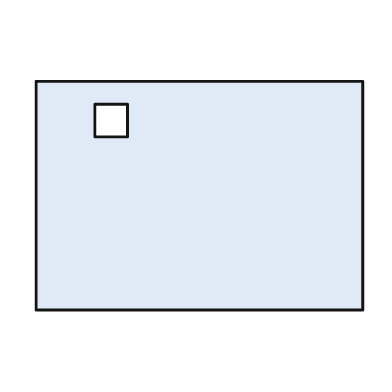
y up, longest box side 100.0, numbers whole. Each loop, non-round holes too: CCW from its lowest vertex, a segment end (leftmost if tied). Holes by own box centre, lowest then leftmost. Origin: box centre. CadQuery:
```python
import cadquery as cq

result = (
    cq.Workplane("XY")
    .moveTo(-50.0, -35.0)
    .lineTo(50.0, -35.0)
    .lineTo(50.0, 35.0)
    .lineTo(-50.0, 35.0)
    .close()
    .moveTo(-32.0, 18.0)
    .lineTo(-22.0, 18.0)
    .lineTo(-22.0, 28.0)
    .lineTo(-32.0, 28.0)
    .close()
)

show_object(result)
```